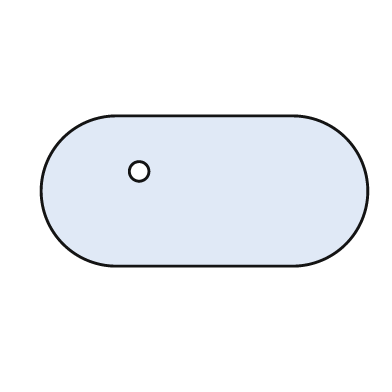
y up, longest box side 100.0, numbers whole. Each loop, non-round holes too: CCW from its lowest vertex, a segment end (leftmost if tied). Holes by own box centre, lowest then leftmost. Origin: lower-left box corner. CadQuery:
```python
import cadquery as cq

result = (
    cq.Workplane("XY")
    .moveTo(23.0, 0.0)
    .lineTo(77.0, 0.0)
    .threePointArc((100.0, 23.0), (77.0, 46.0))
    .lineTo(23.0, 46.0)
    .threePointArc((0.0, 23.0), (23.0, 0.0))
    .close()
    .moveTo(30.0, 29.0)
    .circle(3.0)
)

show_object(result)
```